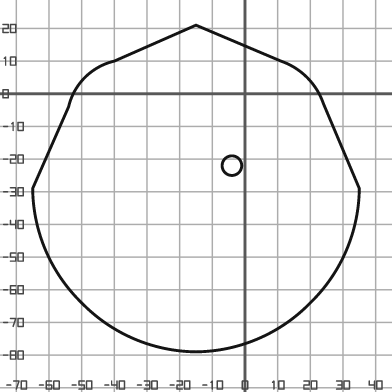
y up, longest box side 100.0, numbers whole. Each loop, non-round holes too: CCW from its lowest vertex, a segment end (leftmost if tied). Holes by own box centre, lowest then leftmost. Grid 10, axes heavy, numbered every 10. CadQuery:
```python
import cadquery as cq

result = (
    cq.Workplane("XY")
    .moveTo(-15.0, -79.0)
    .threePointArc((4.0, -75.0), (20.0, -64.0))
    .threePointArc((31.0, -48.0), (35.0, -29.0))
    .lineTo(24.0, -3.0)
    .threePointArc((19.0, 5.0), (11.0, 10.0))
    .lineTo(-15.0, 21.0)
    .lineTo(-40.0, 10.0)
    .threePointArc((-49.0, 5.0), (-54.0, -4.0))
    .lineTo(-65.0, -29.0)
    .threePointArc((-61.0, -48.0), (-50.0, -64.0))
    .threePointArc((-34.0, -75.0), (-15.0, -79.0))
    .close()
    .moveTo(-4.0, -22.0)
    .circle(3.0)
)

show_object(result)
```